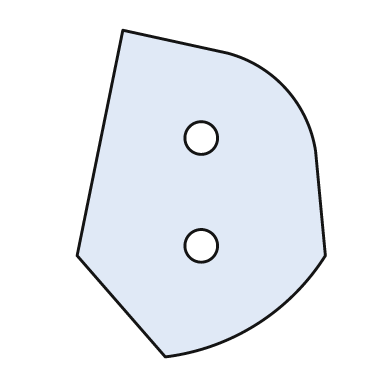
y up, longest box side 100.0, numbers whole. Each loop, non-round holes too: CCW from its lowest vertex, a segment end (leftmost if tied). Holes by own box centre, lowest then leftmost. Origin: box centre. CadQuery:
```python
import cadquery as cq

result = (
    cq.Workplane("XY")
    .moveTo(-11.0, -50.0)
    .threePointArc((17.0, -40.0), (38.0, -19.0))
    .lineTo(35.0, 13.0)
    .threePointArc((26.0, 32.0), (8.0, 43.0))
    .lineTo(-24.0, 50.0)
    .lineTo(-38.0, -19.0)
    .close()
    .moveTo(0.0, -16.0)
    .circle(5.0)
    .moveTo(0.0, 17.0)
    .circle(5.0)
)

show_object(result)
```